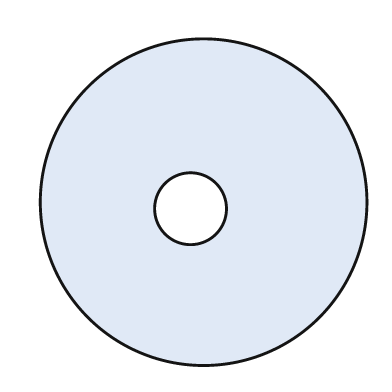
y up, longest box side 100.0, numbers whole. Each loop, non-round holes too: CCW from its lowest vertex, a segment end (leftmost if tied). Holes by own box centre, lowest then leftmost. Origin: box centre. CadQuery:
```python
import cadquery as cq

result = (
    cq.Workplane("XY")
    .moveTo(0.0, 0.0)
    .circle(50.0)
    .moveTo(-4.0, -2.0)
    .circle(11.0)
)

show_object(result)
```